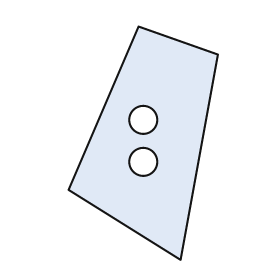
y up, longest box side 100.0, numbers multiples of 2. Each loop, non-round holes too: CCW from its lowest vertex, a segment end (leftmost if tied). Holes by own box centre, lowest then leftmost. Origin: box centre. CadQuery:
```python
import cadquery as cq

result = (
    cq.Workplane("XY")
    .moveTo(16.0, -50.0)
    .lineTo(32.0, 38.0)
    .lineTo(-2.0, 50.0)
    .lineTo(-32.0, -20.0)
    .close()
    .moveTo(0.0, -8.0)
    .circle(6.0)
    .moveTo(0.0, 10.0)
    .circle(6.0)
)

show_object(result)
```